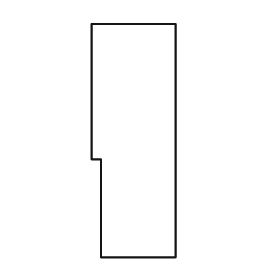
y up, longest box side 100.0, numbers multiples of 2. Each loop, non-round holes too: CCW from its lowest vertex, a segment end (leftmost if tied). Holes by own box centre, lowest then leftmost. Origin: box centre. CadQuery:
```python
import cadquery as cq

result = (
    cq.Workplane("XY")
    .moveTo(-14.0, -50.0)
    .lineTo(18.0, -50.0)
    .lineTo(18.0, 50.0)
    .lineTo(-18.0, 50.0)
    .lineTo(-18.0, -8.0)
    .lineTo(-14.0, -8.0)
    .close()
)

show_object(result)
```